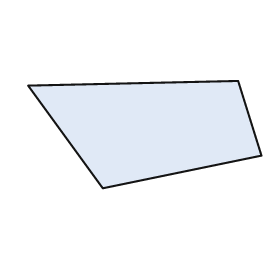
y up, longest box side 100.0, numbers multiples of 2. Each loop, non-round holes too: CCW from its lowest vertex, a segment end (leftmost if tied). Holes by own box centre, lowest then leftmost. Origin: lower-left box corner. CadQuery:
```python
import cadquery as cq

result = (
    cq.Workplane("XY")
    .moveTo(32.0, 0.0)
    .lineTo(100.0, 14.0)
    .lineTo(90.0, 46.0)
    .lineTo(0.0, 44.0)
    .close()
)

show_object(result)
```